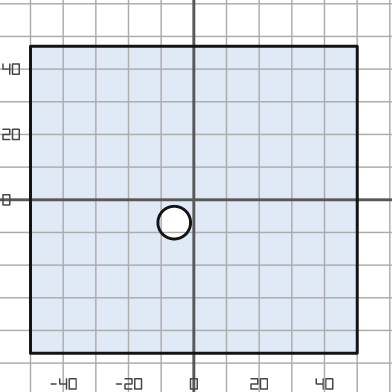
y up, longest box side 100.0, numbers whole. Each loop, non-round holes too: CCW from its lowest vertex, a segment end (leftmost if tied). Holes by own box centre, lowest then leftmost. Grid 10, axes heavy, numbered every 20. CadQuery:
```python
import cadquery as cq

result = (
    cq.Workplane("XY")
    .moveTo(-50.0, -47.0)
    .lineTo(50.0, -47.0)
    .lineTo(50.0, 47.0)
    .lineTo(-50.0, 47.0)
    .close()
    .moveTo(-6.0, -7.0)
    .circle(5.0)
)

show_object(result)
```